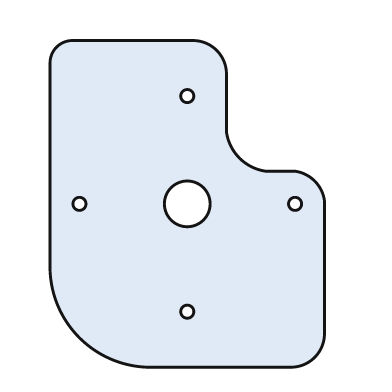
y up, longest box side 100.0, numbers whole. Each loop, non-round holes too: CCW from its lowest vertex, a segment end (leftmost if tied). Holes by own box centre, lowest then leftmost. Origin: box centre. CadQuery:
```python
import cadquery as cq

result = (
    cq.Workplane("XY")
    .moveTo(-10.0, -50.0)
    .lineTo(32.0, -50.0)
    .threePointArc((39.0, -47.0), (42.0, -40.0))
    .lineTo(42.0, 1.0)
    .threePointArc((39.0, 7.0), (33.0, 10.0))
    .lineTo(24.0, 10.0)
    .threePointArc((16.0, 14.0), (12.0, 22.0))
    .lineTo(12.0, 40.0)
    .threePointArc((9.0, 47.0), (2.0, 50.0))
    .lineTo(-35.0, 50.0)
    .threePointArc((-40.0, 48.0), (-42.0, 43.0))
    .lineTo(-42.0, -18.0)
    .threePointArc((-33.0, -41.0), (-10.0, -50.0))
    .close()
    .moveTo(0.0, -33.0)
    .circle(2.0)
    .moveTo(-33.0, 0.0)
    .circle(2.0)
    .moveTo(0.0, 0.0)
    .circle(7.0)
    .moveTo(33.0, 0.0)
    .circle(2.0)
    .moveTo(0.0, 33.0)
    .circle(2.0)
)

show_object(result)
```